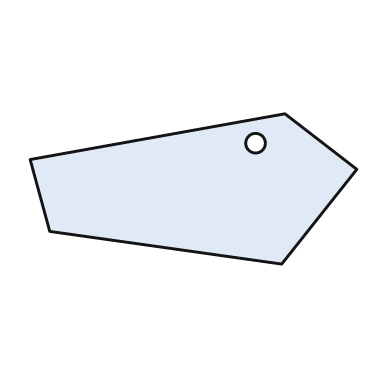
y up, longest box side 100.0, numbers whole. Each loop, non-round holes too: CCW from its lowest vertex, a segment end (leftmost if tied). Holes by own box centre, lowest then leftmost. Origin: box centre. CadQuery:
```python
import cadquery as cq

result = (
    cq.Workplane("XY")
    .moveTo(27.0, -23.0)
    .lineTo(50.0, 6.0)
    .lineTo(28.0, 23.0)
    .lineTo(-50.0, 9.0)
    .lineTo(-44.0, -13.0)
    .close()
    .moveTo(19.0, 14.0)
    .circle(3.0)
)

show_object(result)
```